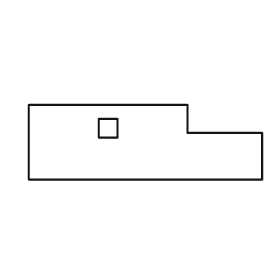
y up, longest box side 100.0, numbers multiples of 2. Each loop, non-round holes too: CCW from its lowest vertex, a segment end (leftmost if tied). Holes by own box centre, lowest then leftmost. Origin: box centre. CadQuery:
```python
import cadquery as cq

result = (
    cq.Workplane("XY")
    .moveTo(-50.0, -16.0)
    .lineTo(50.0, -16.0)
    .lineTo(50.0, 4.0)
    .lineTo(18.0, 4.0)
    .lineTo(18.0, 16.0)
    .lineTo(-50.0, 16.0)
    .close()
    .moveTo(-20.0, 2.0)
    .lineTo(-12.0, 2.0)
    .lineTo(-12.0, 10.0)
    .lineTo(-20.0, 10.0)
    .close()
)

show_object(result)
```